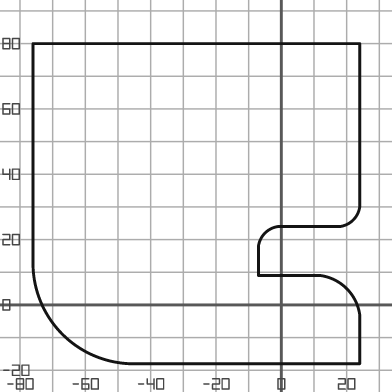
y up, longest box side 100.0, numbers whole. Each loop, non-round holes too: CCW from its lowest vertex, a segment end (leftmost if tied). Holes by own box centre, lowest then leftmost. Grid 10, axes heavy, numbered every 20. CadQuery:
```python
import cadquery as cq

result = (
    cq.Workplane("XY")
    .moveTo(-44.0, -18.0)
    .lineTo(24.0, -18.0)
    .lineTo(24.0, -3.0)
    .threePointArc((20.0, 5.0), (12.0, 9.0))
    .lineTo(-7.0, 9.0)
    .lineTo(-7.0, 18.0)
    .threePointArc((-5.0, 22.0), (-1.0, 24.0))
    .lineTo(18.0, 24.0)
    .threePointArc((22.0, 26.0), (24.0, 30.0))
    .lineTo(24.0, 80.0)
    .lineTo(-76.0, 80.0)
    .lineTo(-76.0, 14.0)
    .threePointArc((-67.0, -9.0), (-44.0, -18.0))
    .close()
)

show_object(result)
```